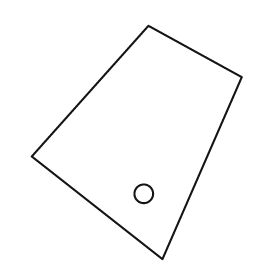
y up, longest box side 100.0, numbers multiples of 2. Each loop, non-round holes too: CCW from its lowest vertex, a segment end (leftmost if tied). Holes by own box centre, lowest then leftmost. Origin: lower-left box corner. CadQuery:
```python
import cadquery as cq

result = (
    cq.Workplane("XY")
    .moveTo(56.0, 0.0)
    .lineTo(90.0, 78.0)
    .lineTo(50.0, 100.0)
    .lineTo(0.0, 44.0)
    .close()
    .moveTo(48.0, 28.0)
    .circle(4.0)
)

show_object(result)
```